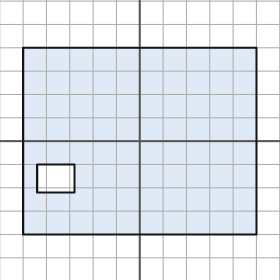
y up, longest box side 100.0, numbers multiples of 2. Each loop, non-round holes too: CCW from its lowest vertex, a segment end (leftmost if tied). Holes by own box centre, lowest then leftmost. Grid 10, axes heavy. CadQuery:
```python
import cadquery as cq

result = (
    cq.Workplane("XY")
    .moveTo(-50.0, -40.0)
    .lineTo(50.0, -40.0)
    .lineTo(50.0, 40.0)
    .lineTo(-50.0, 40.0)
    .close()
    .moveTo(-44.0, -22.0)
    .lineTo(-28.0, -22.0)
    .lineTo(-28.0, -10.0)
    .lineTo(-44.0, -10.0)
    .close()
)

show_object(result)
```